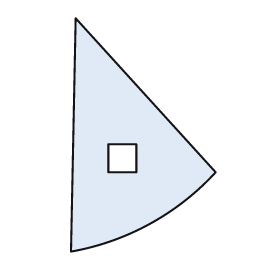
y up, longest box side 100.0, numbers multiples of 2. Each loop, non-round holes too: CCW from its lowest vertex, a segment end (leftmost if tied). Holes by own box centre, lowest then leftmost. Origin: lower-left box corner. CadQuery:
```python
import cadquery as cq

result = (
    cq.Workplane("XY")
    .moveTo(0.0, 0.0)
    .threePointArc((34.0, 12.0), (62.0, 34.0))
    .lineTo(2.0, 100.0)
    .close()
    .moveTo(16.0, 34.0)
    .lineTo(28.0, 34.0)
    .lineTo(28.0, 46.0)
    .lineTo(16.0, 46.0)
    .close()
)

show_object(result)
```